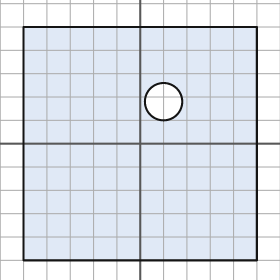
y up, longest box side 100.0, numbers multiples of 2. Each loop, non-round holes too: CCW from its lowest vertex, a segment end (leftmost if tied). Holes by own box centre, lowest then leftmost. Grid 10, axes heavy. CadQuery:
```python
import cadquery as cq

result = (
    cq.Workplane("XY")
    .moveTo(-50.0, -50.0)
    .lineTo(50.0, -50.0)
    .lineTo(50.0, 50.0)
    .lineTo(-50.0, 50.0)
    .close()
    .moveTo(10.0, 18.0)
    .circle(8.0)
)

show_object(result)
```